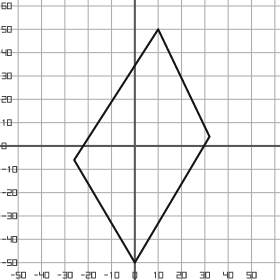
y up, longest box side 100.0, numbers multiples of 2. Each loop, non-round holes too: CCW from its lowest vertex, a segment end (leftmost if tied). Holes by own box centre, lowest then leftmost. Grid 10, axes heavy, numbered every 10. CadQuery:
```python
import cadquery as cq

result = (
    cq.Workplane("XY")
    .moveTo(0.0, -50.0)
    .lineTo(32.0, 4.0)
    .lineTo(10.0, 50.0)
    .lineTo(-26.0, -6.0)
    .close()
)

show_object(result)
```